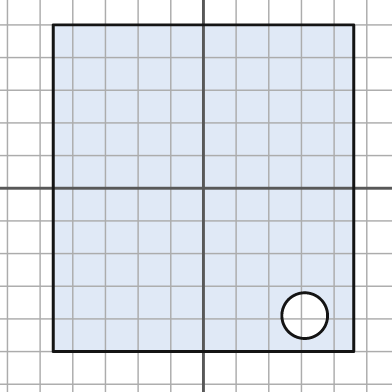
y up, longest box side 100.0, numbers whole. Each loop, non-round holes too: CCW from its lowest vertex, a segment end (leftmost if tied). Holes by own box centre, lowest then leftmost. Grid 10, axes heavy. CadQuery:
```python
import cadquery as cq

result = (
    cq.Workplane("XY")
    .moveTo(-46.0, -50.0)
    .lineTo(46.0, -50.0)
    .lineTo(46.0, 50.0)
    .lineTo(-46.0, 50.0)
    .close()
    .moveTo(31.0, -39.0)
    .circle(7.0)
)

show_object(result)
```